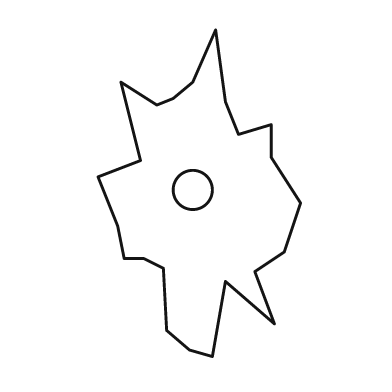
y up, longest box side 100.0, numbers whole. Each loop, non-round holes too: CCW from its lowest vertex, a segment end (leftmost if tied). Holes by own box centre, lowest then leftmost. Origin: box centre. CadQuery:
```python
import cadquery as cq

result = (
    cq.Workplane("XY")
    .moveTo(4.0, -50.0)
    .lineTo(8.0, -27.0)
    .lineTo(23.0, -40.0)
    .lineTo(17.0, -24.0)
    .lineTo(26.0, -18.0)
    .lineTo(31.0, -3.0)
    .lineTo(22.0, 11.0)
    .lineTo(22.0, 21.0)
    .lineTo(12.0, 18.0)
    .lineTo(8.0, 28.0)
    .lineTo(5.0, 50.0)
    .lineTo(-2.0, 34.0)
    .lineTo(-8.0, 29.0)
    .lineTo(-13.0, 27.0)
    .lineTo(-24.0, 34.0)
    .lineTo(-18.0, 10.0)
    .lineTo(-31.0, 5.0)
    .lineTo(-25.0, -10.0)
    .lineTo(-23.0, -20.0)
    .lineTo(-17.0, -20.0)
    .lineTo(-11.0, -23.0)
    .lineTo(-10.0, -42.0)
    .lineTo(-3.0, -48.0)
    .close()
    .moveTo(-2.0, 1.0)
    .circle(6.0)
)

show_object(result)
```